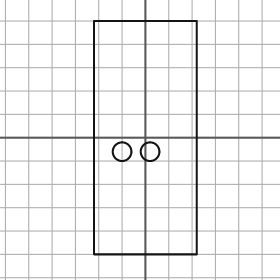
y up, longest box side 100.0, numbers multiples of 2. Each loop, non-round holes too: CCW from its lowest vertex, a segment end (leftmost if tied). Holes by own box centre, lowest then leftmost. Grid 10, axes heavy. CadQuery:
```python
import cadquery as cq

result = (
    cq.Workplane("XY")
    .moveTo(-22.0, -50.0)
    .lineTo(22.0, -50.0)
    .lineTo(22.0, 50.0)
    .lineTo(-22.0, 50.0)
    .close()
    .moveTo(-10.0, -6.0)
    .circle(4.0)
    .moveTo(2.0, -6.0)
    .circle(4.0)
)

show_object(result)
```